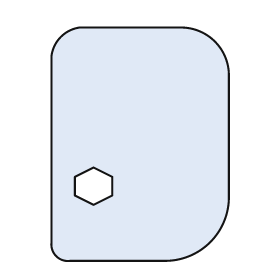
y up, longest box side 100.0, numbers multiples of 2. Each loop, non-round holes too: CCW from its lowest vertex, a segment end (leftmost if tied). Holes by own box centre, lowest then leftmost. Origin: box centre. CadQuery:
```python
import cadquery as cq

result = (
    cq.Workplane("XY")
    .moveTo(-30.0, -50.0)
    .lineTo(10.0, -50.0)
    .threePointArc((30.0, -42.0), (38.0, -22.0))
    .lineTo(38.0, 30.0)
    .threePointArc((32.0, 44.0), (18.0, 50.0))
    .lineTo(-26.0, 50.0)
    .threePointArc((-34.0, 46.0), (-38.0, 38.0))
    .lineTo(-38.0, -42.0)
    .threePointArc((-36.0, -48.0), (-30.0, -50.0))
    .close()
    .moveTo(-20.0, -26.0)
    .lineTo(-12.0, -22.0)
    .lineTo(-12.0, -14.0)
    .lineTo(-20.0, -10.0)
    .lineTo(-28.0, -14.0)
    .lineTo(-28.0, -22.0)
    .close()
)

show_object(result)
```